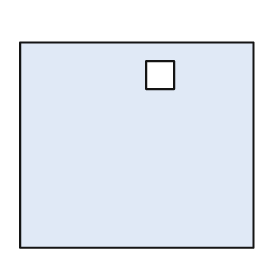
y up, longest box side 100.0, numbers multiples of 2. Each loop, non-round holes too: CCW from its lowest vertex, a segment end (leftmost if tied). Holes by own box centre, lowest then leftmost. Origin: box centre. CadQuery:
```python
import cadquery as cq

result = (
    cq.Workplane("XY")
    .moveTo(-50.0, -44.0)
    .lineTo(50.0, -44.0)
    .lineTo(50.0, 44.0)
    .lineTo(-50.0, 44.0)
    .close()
    .moveTo(4.0, 24.0)
    .lineTo(16.0, 24.0)
    .lineTo(16.0, 36.0)
    .lineTo(4.0, 36.0)
    .close()
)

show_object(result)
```